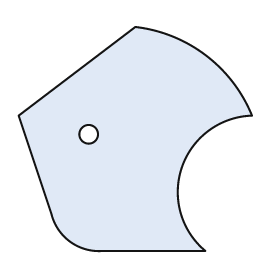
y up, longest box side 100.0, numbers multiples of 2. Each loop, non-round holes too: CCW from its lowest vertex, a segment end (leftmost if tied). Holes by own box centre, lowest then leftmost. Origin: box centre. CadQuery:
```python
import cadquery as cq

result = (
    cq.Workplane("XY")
    .moveTo(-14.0, -48.0)
    .lineTo(30.0, -48.0)
    .threePointArc((20.0, -12.0), (50.0, 10.0))
    .threePointArc((30.0, 36.0), (0.0, 48.0))
    .lineTo(-50.0, 10.0)
    .lineTo(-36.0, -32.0)
    .threePointArc((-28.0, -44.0), (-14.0, -48.0))
    .close()
    .moveTo(-20.0, 2.0)
    .circle(4.0)
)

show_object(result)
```